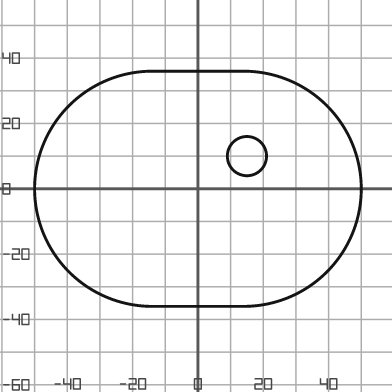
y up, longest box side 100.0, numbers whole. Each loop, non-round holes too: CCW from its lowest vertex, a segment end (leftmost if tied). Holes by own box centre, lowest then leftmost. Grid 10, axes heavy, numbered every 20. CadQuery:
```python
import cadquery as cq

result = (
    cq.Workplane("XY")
    .moveTo(-14.0, -36.0)
    .lineTo(14.0, -36.0)
    .threePointArc((50.0, 0.0), (14.0, 36.0))
    .lineTo(-14.0, 36.0)
    .threePointArc((-50.0, 0.0), (-14.0, -36.0))
    .close()
    .moveTo(15.0, 10.0)
    .circle(6.0)
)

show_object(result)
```